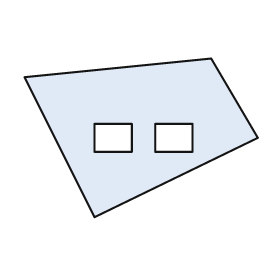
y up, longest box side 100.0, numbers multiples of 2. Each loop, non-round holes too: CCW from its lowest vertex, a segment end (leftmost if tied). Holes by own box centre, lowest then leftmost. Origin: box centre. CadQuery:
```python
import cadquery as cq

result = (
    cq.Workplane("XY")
    .moveTo(-20.0, -34.0)
    .lineTo(50.0, 0.0)
    .lineTo(30.0, 34.0)
    .lineTo(-50.0, 26.0)
    .close()
    .moveTo(-20.0, -6.0)
    .lineTo(-4.0, -6.0)
    .lineTo(-4.0, 6.0)
    .lineTo(-20.0, 6.0)
    .close()
    .moveTo(6.0, -6.0)
    .lineTo(22.0, -6.0)
    .lineTo(22.0, 6.0)
    .lineTo(6.0, 6.0)
    .close()
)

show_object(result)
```